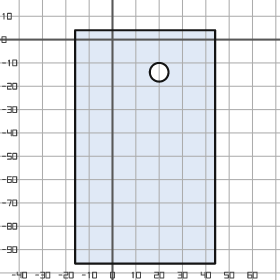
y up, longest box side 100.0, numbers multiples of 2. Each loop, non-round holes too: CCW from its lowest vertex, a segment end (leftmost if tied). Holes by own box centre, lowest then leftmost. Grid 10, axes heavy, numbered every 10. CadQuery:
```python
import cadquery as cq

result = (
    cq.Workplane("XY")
    .moveTo(-16.0, -96.0)
    .lineTo(44.0, -96.0)
    .lineTo(44.0, 4.0)
    .lineTo(-16.0, 4.0)
    .close()
    .moveTo(20.0, -14.0)
    .circle(4.0)
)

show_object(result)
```